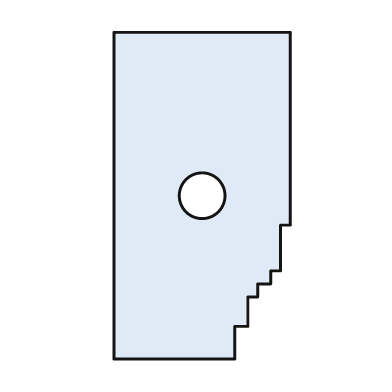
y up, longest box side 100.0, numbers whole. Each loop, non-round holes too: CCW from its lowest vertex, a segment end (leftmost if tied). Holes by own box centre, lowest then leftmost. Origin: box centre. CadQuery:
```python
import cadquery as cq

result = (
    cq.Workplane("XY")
    .moveTo(-27.0, -50.0)
    .lineTo(10.0, -50.0)
    .lineTo(10.0, -40.0)
    .lineTo(14.0, -40.0)
    .lineTo(14.0, -31.0)
    .lineTo(17.0, -31.0)
    .lineTo(17.0, -27.0)
    .lineTo(21.0, -27.0)
    .lineTo(21.0, -23.0)
    .lineTo(24.0, -23.0)
    .lineTo(24.0, -9.0)
    .lineTo(27.0, -9.0)
    .lineTo(27.0, 50.0)
    .lineTo(-27.0, 50.0)
    .close()
    .moveTo(0.0, 0.0)
    .circle(7.0)
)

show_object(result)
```